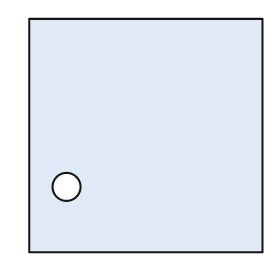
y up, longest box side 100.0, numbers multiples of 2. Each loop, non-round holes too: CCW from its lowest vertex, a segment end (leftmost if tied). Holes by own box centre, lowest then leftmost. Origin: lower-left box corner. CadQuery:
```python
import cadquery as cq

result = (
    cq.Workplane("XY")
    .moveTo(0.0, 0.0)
    .lineTo(100.0, 0.0)
    .lineTo(100.0, 100.0)
    .lineTo(0.0, 100.0)
    .close()
    .moveTo(16.0, 28.0)
    .circle(6.0)
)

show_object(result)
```